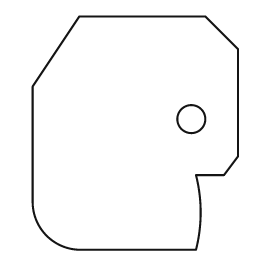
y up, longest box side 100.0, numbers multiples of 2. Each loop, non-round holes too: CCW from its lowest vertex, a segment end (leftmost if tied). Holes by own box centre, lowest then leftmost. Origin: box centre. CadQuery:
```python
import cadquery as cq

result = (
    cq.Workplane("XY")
    .moveTo(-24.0, -50.0)
    .lineTo(26.0, -50.0)
    .threePointArc((28.0, -34.0), (26.0, -18.0))
    .lineTo(38.0, -18.0)
    .lineTo(44.0, -10.0)
    .lineTo(44.0, 36.0)
    .lineTo(30.0, 50.0)
    .lineTo(-24.0, 50.0)
    .lineTo(-44.0, 20.0)
    .lineTo(-44.0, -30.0)
    .threePointArc((-38.0, -44.0), (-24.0, -50.0))
    .close()
    .moveTo(24.0, 6.0)
    .circle(6.0)
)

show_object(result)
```